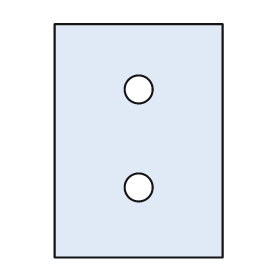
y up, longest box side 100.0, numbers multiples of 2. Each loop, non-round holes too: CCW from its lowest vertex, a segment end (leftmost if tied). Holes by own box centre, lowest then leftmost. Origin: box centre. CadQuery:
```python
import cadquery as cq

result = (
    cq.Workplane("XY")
    .moveTo(-36.0, -50.0)
    .lineTo(36.0, -50.0)
    .lineTo(36.0, 50.0)
    .lineTo(-36.0, 50.0)
    .close()
    .moveTo(0.0, -20.0)
    .circle(6.0)
    .moveTo(0.0, 22.0)
    .circle(6.0)
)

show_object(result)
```